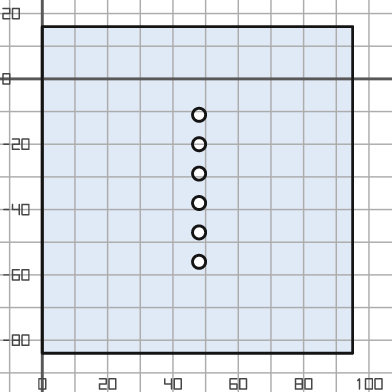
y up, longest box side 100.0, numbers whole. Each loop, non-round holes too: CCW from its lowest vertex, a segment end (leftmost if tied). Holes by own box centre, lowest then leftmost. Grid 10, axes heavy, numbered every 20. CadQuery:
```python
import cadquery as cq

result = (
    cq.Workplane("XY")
    .moveTo(0.0, -84.0)
    .lineTo(95.0, -84.0)
    .lineTo(95.0, 16.0)
    .lineTo(0.0, 16.0)
    .close()
    .moveTo(48.0, -56.0)
    .circle(2.0)
    .moveTo(48.0, -47.0)
    .circle(2.0)
    .moveTo(48.0, -38.0)
    .circle(2.0)
    .moveTo(48.0, -29.0)
    .circle(2.0)
    .moveTo(48.0, -20.0)
    .circle(2.0)
    .moveTo(48.0, -11.0)
    .circle(2.0)
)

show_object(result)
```